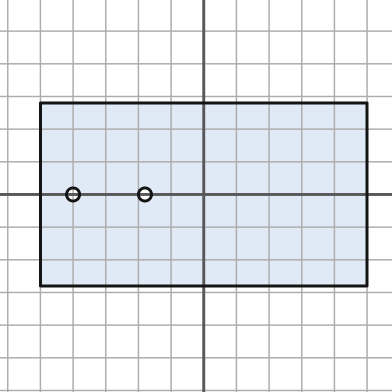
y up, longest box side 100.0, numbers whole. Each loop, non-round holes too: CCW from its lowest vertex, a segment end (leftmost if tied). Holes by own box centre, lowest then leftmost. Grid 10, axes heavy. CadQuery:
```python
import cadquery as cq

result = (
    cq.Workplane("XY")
    .moveTo(-50.0, -28.0)
    .lineTo(50.0, -28.0)
    .lineTo(50.0, 28.0)
    .lineTo(-50.0, 28.0)
    .close()
    .moveTo(-40.0, 0.0)
    .circle(2.0)
    .moveTo(-18.0, 0.0)
    .circle(2.0)
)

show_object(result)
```